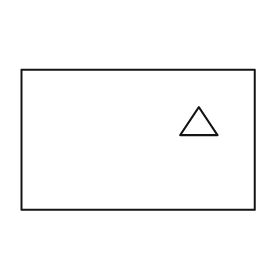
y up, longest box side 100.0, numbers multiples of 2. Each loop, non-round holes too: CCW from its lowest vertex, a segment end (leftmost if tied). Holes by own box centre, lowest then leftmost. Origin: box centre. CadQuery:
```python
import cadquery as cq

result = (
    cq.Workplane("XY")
    .moveTo(-50.0, -30.0)
    .lineTo(50.0, -30.0)
    .lineTo(50.0, 30.0)
    .lineTo(-50.0, 30.0)
    .close()
    .moveTo(18.0, 2.0)
    .lineTo(34.0, 2.0)
    .lineTo(26.0, 14.0)
    .close()
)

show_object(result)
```